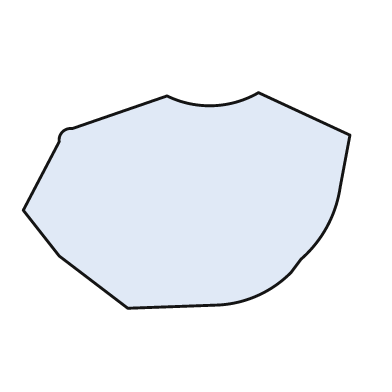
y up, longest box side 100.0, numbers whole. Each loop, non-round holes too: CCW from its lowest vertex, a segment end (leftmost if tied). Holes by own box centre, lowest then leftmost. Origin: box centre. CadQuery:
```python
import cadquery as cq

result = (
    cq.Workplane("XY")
    .moveTo(-18.0, -33.0)
    .lineTo(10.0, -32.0)
    .threePointArc((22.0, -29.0), (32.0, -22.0))
    .lineTo(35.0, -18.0)
    .threePointArc((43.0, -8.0), (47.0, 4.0))
    .lineTo(50.0, 20.0)
    .lineTo(22.0, 33.0)
    .threePointArc((8.0, 29.0), (-6.0, 32.0))
    .lineTo(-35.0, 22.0)
    .threePointArc((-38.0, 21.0), (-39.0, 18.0))
    .lineTo(-50.0, -3.0)
    .lineTo(-39.0, -17.0)
    .close()
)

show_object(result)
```